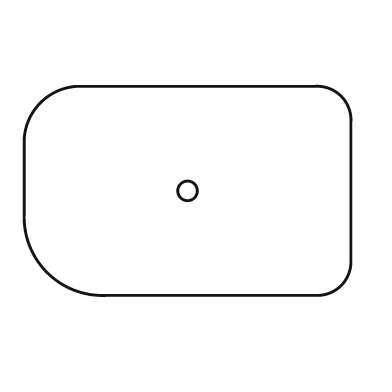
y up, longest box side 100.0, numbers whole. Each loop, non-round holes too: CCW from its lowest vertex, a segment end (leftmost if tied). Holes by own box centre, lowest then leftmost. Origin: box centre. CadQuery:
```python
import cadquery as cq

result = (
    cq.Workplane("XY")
    .moveTo(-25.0, -32.0)
    .lineTo(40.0, -32.0)
    .threePointArc((47.0, -29.0), (50.0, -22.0))
    .lineTo(50.0, 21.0)
    .threePointArc((47.0, 29.0), (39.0, 32.0))
    .lineTo(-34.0, 32.0)
    .threePointArc((-45.0, 27.0), (-50.0, 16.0))
    .lineTo(-50.0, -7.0)
    .threePointArc((-43.0, -25.0), (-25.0, -32.0))
    .close()
    .moveTo(0.0, 0.0)
    .circle(3.0)
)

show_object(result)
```